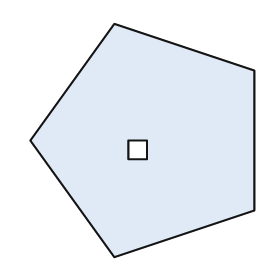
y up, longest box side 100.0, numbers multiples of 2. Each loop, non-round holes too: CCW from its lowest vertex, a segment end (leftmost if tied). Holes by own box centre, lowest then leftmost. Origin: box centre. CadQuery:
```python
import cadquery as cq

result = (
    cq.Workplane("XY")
    .moveTo(-12.0, -50.0)
    .lineTo(48.0, -30.0)
    .lineTo(48.0, 30.0)
    .lineTo(-12.0, 50.0)
    .lineTo(-48.0, 0.0)
    .close()
    .moveTo(-6.0, -8.0)
    .lineTo(2.0, -8.0)
    .lineTo(2.0, 0.0)
    .lineTo(-6.0, 0.0)
    .close()
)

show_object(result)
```